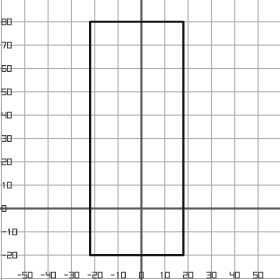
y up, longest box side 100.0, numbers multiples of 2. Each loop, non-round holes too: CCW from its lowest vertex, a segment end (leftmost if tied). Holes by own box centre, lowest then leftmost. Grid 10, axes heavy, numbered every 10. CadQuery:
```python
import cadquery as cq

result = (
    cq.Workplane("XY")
    .moveTo(-22.0, -20.0)
    .lineTo(18.0, -20.0)
    .lineTo(18.0, 80.0)
    .lineTo(-22.0, 80.0)
    .close()
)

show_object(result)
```